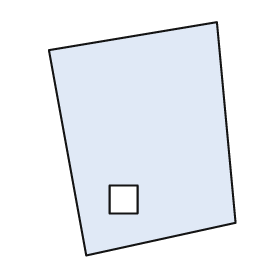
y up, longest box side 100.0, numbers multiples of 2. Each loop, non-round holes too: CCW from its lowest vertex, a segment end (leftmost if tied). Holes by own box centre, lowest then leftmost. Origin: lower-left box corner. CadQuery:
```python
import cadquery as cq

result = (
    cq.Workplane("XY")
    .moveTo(16.0, 0.0)
    .lineTo(80.0, 14.0)
    .lineTo(72.0, 100.0)
    .lineTo(0.0, 88.0)
    .close()
    .moveTo(26.0, 18.0)
    .lineTo(38.0, 18.0)
    .lineTo(38.0, 30.0)
    .lineTo(26.0, 30.0)
    .close()
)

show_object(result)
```